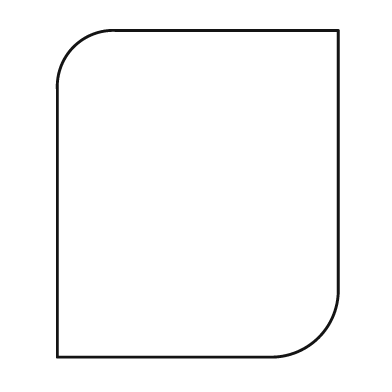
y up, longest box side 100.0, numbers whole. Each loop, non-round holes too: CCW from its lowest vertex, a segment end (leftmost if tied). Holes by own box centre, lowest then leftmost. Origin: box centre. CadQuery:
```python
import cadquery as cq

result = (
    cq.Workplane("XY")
    .moveTo(-43.0, -50.0)
    .lineTo(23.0, -50.0)
    .threePointArc((37.0, -44.0), (43.0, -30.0))
    .lineTo(43.0, 50.0)
    .lineTo(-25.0, 50.0)
    .threePointArc((-38.0, 45.0), (-43.0, 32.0))
    .close()
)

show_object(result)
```